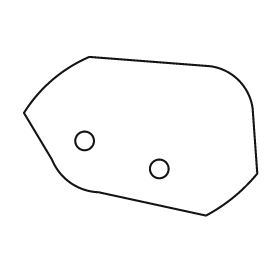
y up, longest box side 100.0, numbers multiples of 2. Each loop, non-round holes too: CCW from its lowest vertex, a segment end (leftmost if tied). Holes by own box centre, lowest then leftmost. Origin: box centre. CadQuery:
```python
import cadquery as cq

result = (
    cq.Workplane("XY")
    .moveTo(28.0, -34.0)
    .threePointArc((40.0, -26.0), (50.0, -16.0))
    .lineTo(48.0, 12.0)
    .threePointArc((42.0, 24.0), (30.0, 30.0))
    .lineTo(-22.0, 34.0)
    .threePointArc((-38.0, 24.0), (-50.0, 10.0))
    .lineTo(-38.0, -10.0)
    .threePointArc((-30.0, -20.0), (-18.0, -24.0))
    .close()
    .moveTo(8.0, -14.0)
    .circle(4.0)
    .moveTo(-24.0, -2.0)
    .circle(4.0)
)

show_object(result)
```